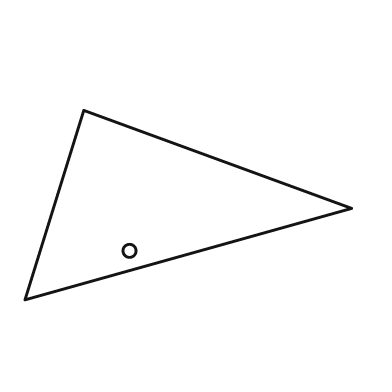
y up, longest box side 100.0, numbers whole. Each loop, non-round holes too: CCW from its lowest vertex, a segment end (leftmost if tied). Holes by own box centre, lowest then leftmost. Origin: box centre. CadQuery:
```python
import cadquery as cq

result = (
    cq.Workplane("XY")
    .moveTo(-50.0, -29.0)
    .lineTo(50.0, -1.0)
    .lineTo(-32.0, 29.0)
    .close()
    .moveTo(-18.0, -14.0)
    .circle(2.0)
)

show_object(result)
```